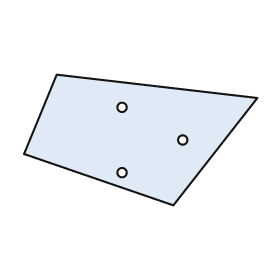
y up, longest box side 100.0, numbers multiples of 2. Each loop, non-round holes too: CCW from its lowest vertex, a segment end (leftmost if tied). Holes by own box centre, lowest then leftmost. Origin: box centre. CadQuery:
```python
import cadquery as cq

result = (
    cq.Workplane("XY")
    .moveTo(14.0, -28.0)
    .lineTo(50.0, 18.0)
    .lineTo(-36.0, 28.0)
    .lineTo(-50.0, -6.0)
    .close()
    .moveTo(-8.0, -14.0)
    .circle(2.0)
    .moveTo(18.0, 0.0)
    .circle(2.0)
    .moveTo(-8.0, 14.0)
    .circle(2.0)
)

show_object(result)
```